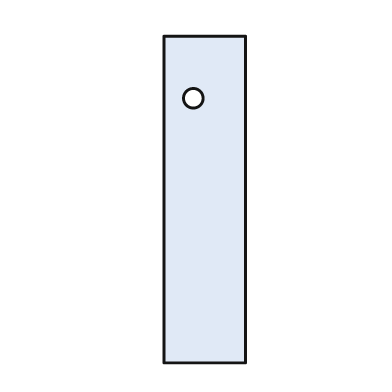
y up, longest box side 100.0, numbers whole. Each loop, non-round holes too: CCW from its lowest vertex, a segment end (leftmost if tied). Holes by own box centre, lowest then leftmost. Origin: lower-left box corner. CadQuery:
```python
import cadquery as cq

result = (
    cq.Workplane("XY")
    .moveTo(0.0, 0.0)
    .lineTo(25.0, 0.0)
    .lineTo(25.0, 100.0)
    .lineTo(0.0, 100.0)
    .close()
    .moveTo(9.0, 81.0)
    .circle(3.0)
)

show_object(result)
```